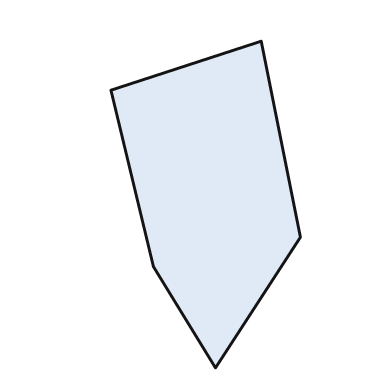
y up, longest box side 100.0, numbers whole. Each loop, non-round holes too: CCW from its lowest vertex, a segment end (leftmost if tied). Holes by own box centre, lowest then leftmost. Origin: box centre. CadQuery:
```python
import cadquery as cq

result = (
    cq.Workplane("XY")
    .moveTo(3.0, -50.0)
    .lineTo(29.0, -10.0)
    .lineTo(17.0, 50.0)
    .lineTo(-29.0, 35.0)
    .lineTo(-16.0, -19.0)
    .close()
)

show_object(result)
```